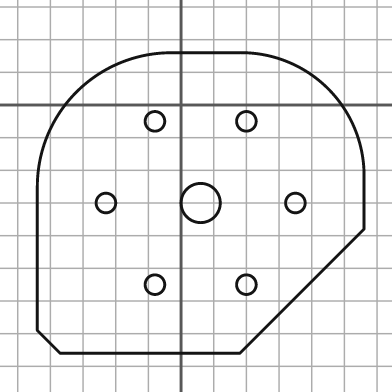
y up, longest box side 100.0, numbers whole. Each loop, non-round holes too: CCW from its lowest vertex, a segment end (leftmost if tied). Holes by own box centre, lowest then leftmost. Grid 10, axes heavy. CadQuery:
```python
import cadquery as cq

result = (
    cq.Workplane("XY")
    .moveTo(-37.0, -76.0)
    .lineTo(18.0, -76.0)
    .lineTo(56.0, -38.0)
    .lineTo(56.0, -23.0)
    .threePointArc((45.0, 5.0), (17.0, 16.0))
    .lineTo(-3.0, 16.0)
    .threePointArc((-32.0, 4.0), (-44.0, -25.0))
    .lineTo(-44.0, -69.0)
    .close()
    .moveTo(-8.0, -55.0)
    .circle(3.0)
    .moveTo(20.0, -55.0)
    .circle(3.0)
    .moveTo(-23.0, -30.0)
    .circle(3.0)
    .moveTo(6.0, -30.0)
    .circle(6.0)
    .moveTo(35.0, -30.0)
    .circle(3.0)
    .moveTo(-8.0, -5.0)
    .circle(3.0)
    .moveTo(20.0, -5.0)
    .circle(3.0)
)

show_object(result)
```